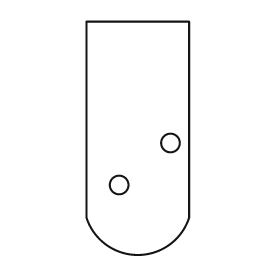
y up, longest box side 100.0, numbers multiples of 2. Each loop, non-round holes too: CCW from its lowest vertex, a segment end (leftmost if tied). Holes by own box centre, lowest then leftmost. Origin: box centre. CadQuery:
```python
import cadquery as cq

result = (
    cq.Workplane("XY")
    .moveTo(-22.0, -34.0)
    .threePointArc((0.0, -50.0), (22.0, -34.0))
    .lineTo(22.0, 50.0)
    .lineTo(-22.0, 50.0)
    .close()
    .moveTo(-8.0, -20.0)
    .circle(4.0)
    .moveTo(14.0, -2.0)
    .circle(4.0)
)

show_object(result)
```